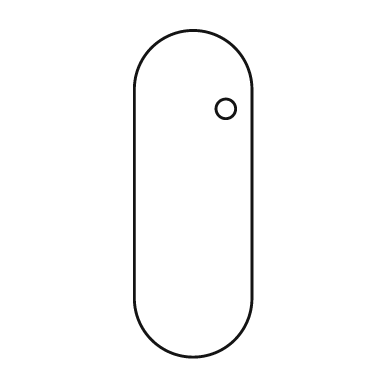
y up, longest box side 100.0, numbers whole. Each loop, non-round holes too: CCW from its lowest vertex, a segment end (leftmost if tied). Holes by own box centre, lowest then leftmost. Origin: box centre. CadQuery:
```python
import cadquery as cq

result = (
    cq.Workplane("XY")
    .moveTo(-18.0, -32.0)
    .threePointArc((0.0, -50.0), (18.0, -32.0))
    .lineTo(18.0, 32.0)
    .threePointArc((0.0, 50.0), (-18.0, 32.0))
    .close()
    .moveTo(10.0, 26.0)
    .circle(3.0)
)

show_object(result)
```